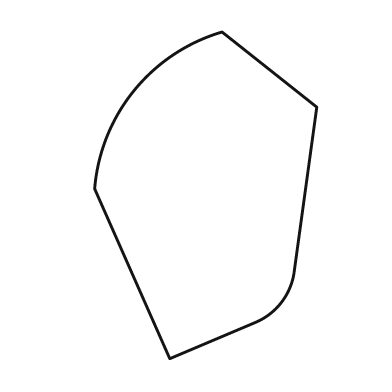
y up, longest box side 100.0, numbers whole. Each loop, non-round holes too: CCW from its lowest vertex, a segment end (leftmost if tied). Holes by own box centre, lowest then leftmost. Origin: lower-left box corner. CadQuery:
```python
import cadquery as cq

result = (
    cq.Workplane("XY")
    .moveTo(23.0, 0.0)
    .lineTo(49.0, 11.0)
    .threePointArc((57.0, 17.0), (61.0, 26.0))
    .lineTo(68.0, 77.0)
    .lineTo(39.0, 100.0)
    .threePointArc((12.0, 82.0), (0.0, 52.0))
    .close()
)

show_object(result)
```